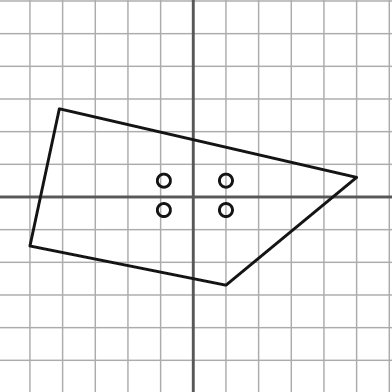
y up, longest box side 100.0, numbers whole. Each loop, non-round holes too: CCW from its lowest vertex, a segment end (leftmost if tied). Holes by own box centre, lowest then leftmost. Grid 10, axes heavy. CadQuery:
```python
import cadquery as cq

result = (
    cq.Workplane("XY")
    .moveTo(10.0, -27.0)
    .lineTo(50.0, 6.0)
    .lineTo(-41.0, 27.0)
    .lineTo(-50.0, -15.0)
    .close()
    .moveTo(-9.0, -4.0)
    .circle(2.0)
    .moveTo(10.0, -4.0)
    .circle(2.0)
    .moveTo(-9.0, 5.0)
    .circle(2.0)
    .moveTo(10.0, 5.0)
    .circle(2.0)
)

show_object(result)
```